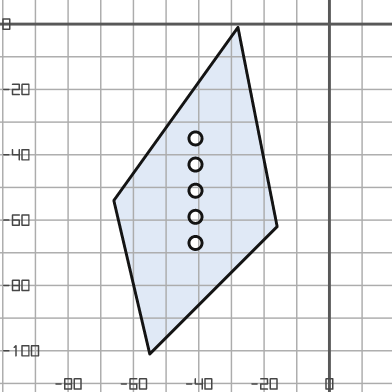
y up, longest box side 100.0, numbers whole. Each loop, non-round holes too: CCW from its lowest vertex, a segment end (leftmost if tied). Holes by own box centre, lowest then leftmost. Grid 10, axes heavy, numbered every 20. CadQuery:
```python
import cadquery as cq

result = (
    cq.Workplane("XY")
    .moveTo(-55.0, -101.0)
    .lineTo(-16.0, -62.0)
    .lineTo(-28.0, -1.0)
    .lineTo(-66.0, -54.0)
    .close()
    .moveTo(-41.0, -67.0)
    .circle(2.0)
    .moveTo(-41.0, -59.0)
    .circle(2.0)
    .moveTo(-41.0, -51.0)
    .circle(2.0)
    .moveTo(-41.0, -43.0)
    .circle(2.0)
    .moveTo(-41.0, -35.0)
    .circle(2.0)
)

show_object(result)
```